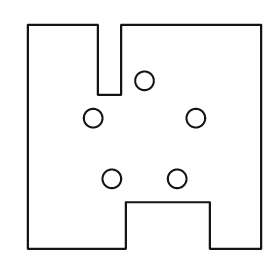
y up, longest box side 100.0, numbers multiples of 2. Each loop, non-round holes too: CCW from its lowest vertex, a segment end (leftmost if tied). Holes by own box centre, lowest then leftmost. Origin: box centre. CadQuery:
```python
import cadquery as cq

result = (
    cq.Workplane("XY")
    .moveTo(-50.0, -48.0)
    .lineTo(-8.0, -48.0)
    .lineTo(-8.0, -28.0)
    .lineTo(28.0, -28.0)
    .lineTo(28.0, -48.0)
    .lineTo(50.0, -48.0)
    .lineTo(50.0, 48.0)
    .lineTo(-10.0, 48.0)
    .lineTo(-10.0, 18.0)
    .lineTo(-20.0, 18.0)
    .lineTo(-20.0, 48.0)
    .lineTo(-50.0, 48.0)
    .close()
    .moveTo(-14.0, -18.0)
    .circle(4.0)
    .moveTo(14.0, -18.0)
    .circle(4.0)
    .moveTo(-22.0, 8.0)
    .circle(4.0)
    .moveTo(22.0, 8.0)
    .circle(4.0)
    .moveTo(0.0, 24.0)
    .circle(4.0)
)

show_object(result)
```